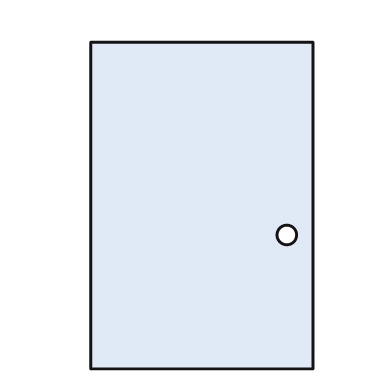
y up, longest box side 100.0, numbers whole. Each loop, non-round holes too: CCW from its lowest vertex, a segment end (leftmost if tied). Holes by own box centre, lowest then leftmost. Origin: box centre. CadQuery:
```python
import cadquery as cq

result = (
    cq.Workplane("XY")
    .moveTo(-34.0, -50.0)
    .lineTo(34.0, -50.0)
    .lineTo(34.0, 50.0)
    .lineTo(-34.0, 50.0)
    .close()
    .moveTo(26.0, -9.0)
    .circle(3.0)
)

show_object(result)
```